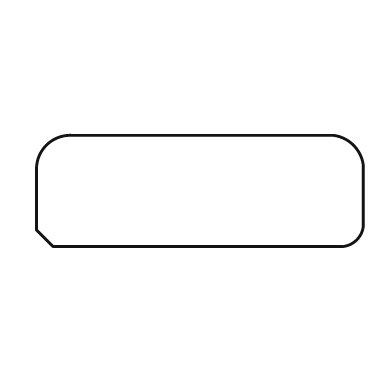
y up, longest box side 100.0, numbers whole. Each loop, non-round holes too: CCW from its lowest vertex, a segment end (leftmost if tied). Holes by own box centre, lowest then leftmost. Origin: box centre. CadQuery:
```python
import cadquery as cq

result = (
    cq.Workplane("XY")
    .moveTo(-45.0, -17.0)
    .lineTo(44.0, -17.0)
    .threePointArc((48.0, -15.0), (50.0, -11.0))
    .lineTo(50.0, 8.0)
    .threePointArc((47.0, 14.0), (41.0, 17.0))
    .lineTo(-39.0, 17.0)
    .threePointArc((-47.0, 14.0), (-50.0, 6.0))
    .lineTo(-50.0, -12.0)
    .close()
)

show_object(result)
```